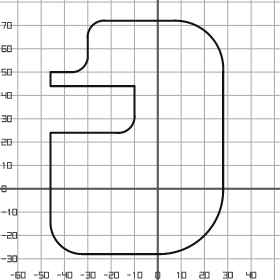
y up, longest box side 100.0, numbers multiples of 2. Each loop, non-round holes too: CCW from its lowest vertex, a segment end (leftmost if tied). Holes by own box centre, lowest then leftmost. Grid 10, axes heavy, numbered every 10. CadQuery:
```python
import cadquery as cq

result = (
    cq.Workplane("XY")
    .moveTo(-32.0, -28.0)
    .lineTo(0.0, -28.0)
    .threePointArc((20.0, -20.0), (28.0, 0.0))
    .lineTo(28.0, 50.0)
    .threePointArc((22.0, 66.0), (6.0, 72.0))
    .lineTo(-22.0, 72.0)
    .threePointArc((-28.0, 70.0), (-30.0, 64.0))
    .lineTo(-30.0, 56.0)
    .threePointArc((-32.0, 52.0), (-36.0, 50.0))
    .lineTo(-46.0, 50.0)
    .lineTo(-46.0, 44.0)
    .lineTo(-10.0, 44.0)
    .lineTo(-10.0, 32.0)
    .threePointArc((-12.0, 26.0), (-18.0, 24.0))
    .lineTo(-46.0, 24.0)
    .lineTo(-46.0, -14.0)
    .threePointArc((-42.0, -24.0), (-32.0, -28.0))
    .close()
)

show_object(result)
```